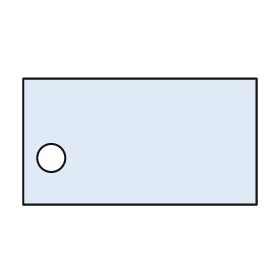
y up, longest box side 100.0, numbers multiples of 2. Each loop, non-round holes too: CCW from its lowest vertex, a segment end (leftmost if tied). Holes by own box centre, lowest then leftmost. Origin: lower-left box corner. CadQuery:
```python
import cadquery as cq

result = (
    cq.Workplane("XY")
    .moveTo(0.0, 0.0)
    .lineTo(100.0, 0.0)
    .lineTo(100.0, 54.0)
    .lineTo(0.0, 54.0)
    .close()
    .moveTo(12.0, 20.0)
    .circle(6.0)
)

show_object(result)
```